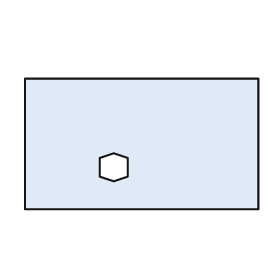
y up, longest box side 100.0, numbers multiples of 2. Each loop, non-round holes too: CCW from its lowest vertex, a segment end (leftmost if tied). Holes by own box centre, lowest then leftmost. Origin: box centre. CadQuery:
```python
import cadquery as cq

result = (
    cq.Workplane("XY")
    .moveTo(-50.0, -28.0)
    .lineTo(50.0, -28.0)
    .lineTo(50.0, 28.0)
    .lineTo(-50.0, 28.0)
    .close()
    .moveTo(-12.0, -16.0)
    .lineTo(-6.0, -14.0)
    .lineTo(-6.0, -6.0)
    .lineTo(-12.0, -4.0)
    .lineTo(-18.0, -6.0)
    .lineTo(-18.0, -14.0)
    .close()
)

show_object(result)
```